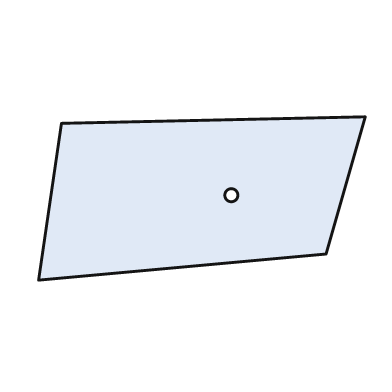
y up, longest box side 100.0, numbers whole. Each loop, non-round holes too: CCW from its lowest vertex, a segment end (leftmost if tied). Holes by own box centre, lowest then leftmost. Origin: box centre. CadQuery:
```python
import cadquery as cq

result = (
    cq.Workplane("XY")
    .moveTo(-50.0, -25.0)
    .lineTo(38.0, -17.0)
    .lineTo(50.0, 25.0)
    .lineTo(-43.0, 23.0)
    .close()
    .moveTo(9.0, 1.0)
    .circle(2.0)
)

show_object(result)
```